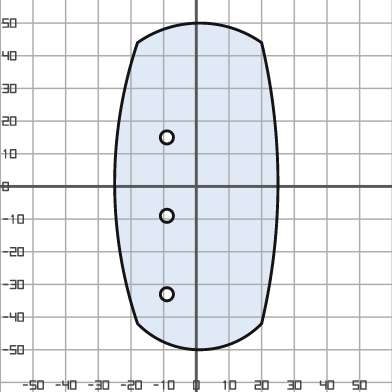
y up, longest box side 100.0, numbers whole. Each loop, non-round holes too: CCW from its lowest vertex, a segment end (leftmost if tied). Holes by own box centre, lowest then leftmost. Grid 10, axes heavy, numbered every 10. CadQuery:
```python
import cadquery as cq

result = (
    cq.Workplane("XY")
    .moveTo(-18.0, -42.0)
    .threePointArc((1.0, -50.0), (20.0, -42.0))
    .threePointArc((25.0, 1.0), (20.0, 44.0))
    .threePointArc((1.0, 50.0), (-18.0, 44.0))
    .threePointArc((-25.0, 1.0), (-18.0, -42.0))
    .close()
    .moveTo(-9.0, -33.0)
    .circle(2.0)
    .moveTo(-9.0, -9.0)
    .circle(2.0)
    .moveTo(-9.0, 15.0)
    .circle(2.0)
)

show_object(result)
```